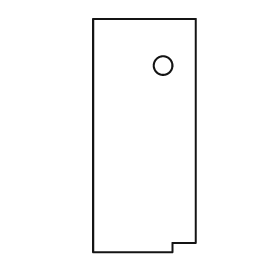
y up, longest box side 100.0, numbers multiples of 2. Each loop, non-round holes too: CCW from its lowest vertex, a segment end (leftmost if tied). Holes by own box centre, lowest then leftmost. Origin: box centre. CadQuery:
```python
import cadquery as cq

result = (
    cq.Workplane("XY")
    .moveTo(-22.0, -50.0)
    .lineTo(12.0, -50.0)
    .lineTo(12.0, -46.0)
    .lineTo(22.0, -46.0)
    .lineTo(22.0, 50.0)
    .lineTo(-22.0, 50.0)
    .close()
    .moveTo(8.0, 30.0)
    .circle(4.0)
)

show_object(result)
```